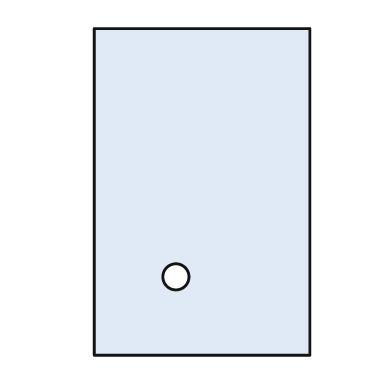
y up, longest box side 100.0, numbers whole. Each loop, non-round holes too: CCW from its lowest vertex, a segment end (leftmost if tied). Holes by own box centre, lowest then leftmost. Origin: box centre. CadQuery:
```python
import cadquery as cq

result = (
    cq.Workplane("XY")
    .moveTo(-33.0, -50.0)
    .lineTo(33.0, -50.0)
    .lineTo(33.0, 50.0)
    .lineTo(-33.0, 50.0)
    .close()
    .moveTo(-8.0, -26.0)
    .circle(4.0)
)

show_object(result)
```